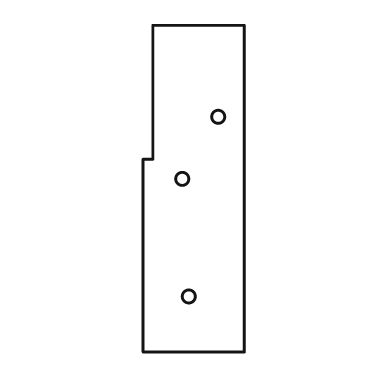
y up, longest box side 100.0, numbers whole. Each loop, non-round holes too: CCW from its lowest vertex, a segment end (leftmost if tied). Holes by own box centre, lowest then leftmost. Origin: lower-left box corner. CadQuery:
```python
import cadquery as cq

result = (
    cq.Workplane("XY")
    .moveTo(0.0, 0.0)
    .lineTo(31.0, 0.0)
    .lineTo(31.0, 100.0)
    .lineTo(3.0, 100.0)
    .lineTo(3.0, 59.0)
    .lineTo(0.0, 59.0)
    .close()
    .moveTo(14.0, 17.0)
    .circle(2.0)
    .moveTo(12.0, 53.0)
    .circle(2.0)
    .moveTo(23.0, 72.0)
    .circle(2.0)
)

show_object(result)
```